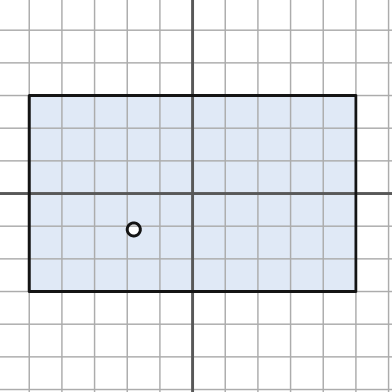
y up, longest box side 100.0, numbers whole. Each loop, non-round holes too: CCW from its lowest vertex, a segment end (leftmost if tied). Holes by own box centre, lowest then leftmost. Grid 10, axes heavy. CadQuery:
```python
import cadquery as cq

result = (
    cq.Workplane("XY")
    .moveTo(-50.0, -30.0)
    .lineTo(50.0, -30.0)
    .lineTo(50.0, 30.0)
    .lineTo(-50.0, 30.0)
    .close()
    .moveTo(-18.0, -11.0)
    .circle(2.0)
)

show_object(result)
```